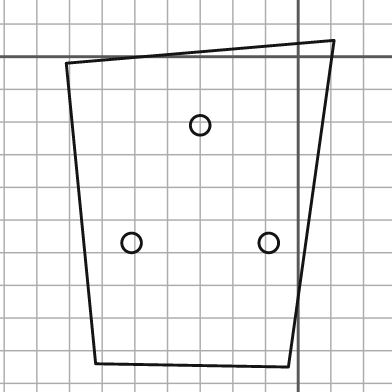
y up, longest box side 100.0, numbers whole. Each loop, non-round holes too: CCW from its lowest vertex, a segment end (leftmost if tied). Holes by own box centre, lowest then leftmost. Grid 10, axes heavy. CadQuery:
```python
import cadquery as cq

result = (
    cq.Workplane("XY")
    .moveTo(-3.0, -95.0)
    .lineTo(11.0, 5.0)
    .lineTo(-71.0, -2.0)
    .lineTo(-62.0, -94.0)
    .close()
    .moveTo(-51.0, -57.0)
    .circle(3.0)
    .moveTo(-9.0, -57.0)
    .circle(3.0)
    .moveTo(-30.0, -21.0)
    .circle(3.0)
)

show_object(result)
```